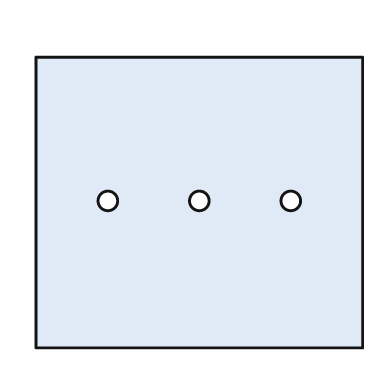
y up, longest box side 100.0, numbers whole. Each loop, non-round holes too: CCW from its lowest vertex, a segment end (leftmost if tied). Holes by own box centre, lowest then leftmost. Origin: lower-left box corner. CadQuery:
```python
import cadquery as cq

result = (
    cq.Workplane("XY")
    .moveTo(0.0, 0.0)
    .lineTo(100.0, 0.0)
    .lineTo(100.0, 89.0)
    .lineTo(0.0, 89.0)
    .close()
    .moveTo(22.0, 45.0)
    .circle(3.0)
    .moveTo(50.0, 45.0)
    .circle(3.0)
    .moveTo(78.0, 45.0)
    .circle(3.0)
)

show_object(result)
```